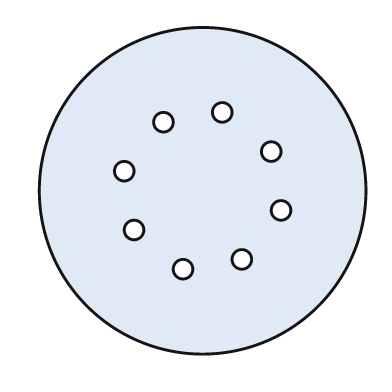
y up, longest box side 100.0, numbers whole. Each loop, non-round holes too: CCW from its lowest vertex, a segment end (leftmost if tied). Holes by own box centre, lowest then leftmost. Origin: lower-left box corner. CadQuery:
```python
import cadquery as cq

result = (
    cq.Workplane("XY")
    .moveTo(50.0, 50.0)
    .circle(50.0)
    .moveTo(44.0, 26.0)
    .circle(3.0)
    .moveTo(62.0, 29.0)
    .circle(3.0)
    .moveTo(29.0, 38.0)
    .circle(3.0)
    .moveTo(74.0, 44.0)
    .circle(3.0)
    .moveTo(26.0, 56.0)
    .circle(3.0)
    .moveTo(71.0, 62.0)
    .circle(3.0)
    .moveTo(38.0, 71.0)
    .circle(3.0)
    .moveTo(56.0, 74.0)
    .circle(3.0)
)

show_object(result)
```